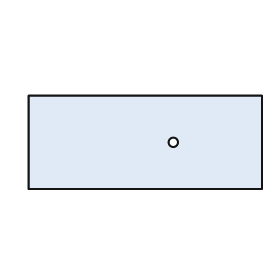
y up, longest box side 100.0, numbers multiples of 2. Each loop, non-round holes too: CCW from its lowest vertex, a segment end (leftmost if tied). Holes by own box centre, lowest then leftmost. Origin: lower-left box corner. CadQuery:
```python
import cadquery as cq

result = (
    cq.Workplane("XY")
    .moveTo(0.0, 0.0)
    .lineTo(100.0, 0.0)
    .lineTo(100.0, 40.0)
    .lineTo(0.0, 40.0)
    .close()
    .moveTo(62.0, 20.0)
    .circle(2.0)
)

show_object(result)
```